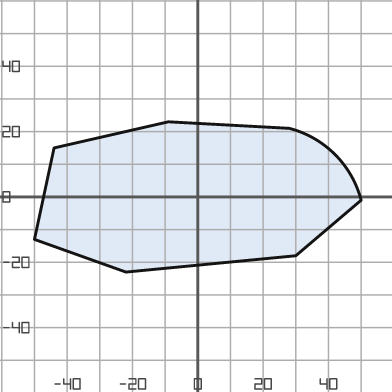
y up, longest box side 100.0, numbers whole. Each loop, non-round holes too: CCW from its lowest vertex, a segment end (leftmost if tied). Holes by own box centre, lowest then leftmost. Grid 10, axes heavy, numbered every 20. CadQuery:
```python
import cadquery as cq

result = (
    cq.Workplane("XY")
    .moveTo(-22.0, -23.0)
    .lineTo(30.0, -18.0)
    .lineTo(50.0, -1.0)
    .threePointArc((42.0, 13.0), (28.0, 21.0))
    .lineTo(-9.0, 23.0)
    .lineTo(-44.0, 15.0)
    .lineTo(-50.0, -13.0)
    .close()
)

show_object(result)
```